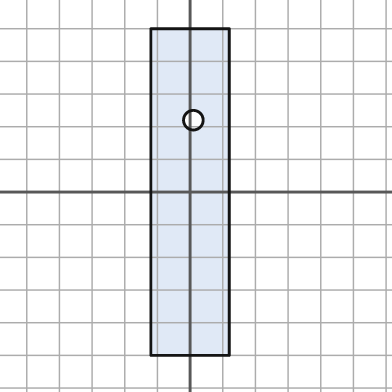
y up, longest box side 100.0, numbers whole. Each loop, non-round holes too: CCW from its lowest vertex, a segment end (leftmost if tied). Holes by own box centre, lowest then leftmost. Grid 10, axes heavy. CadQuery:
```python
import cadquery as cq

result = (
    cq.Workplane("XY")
    .moveTo(-12.0, -50.0)
    .lineTo(12.0, -50.0)
    .lineTo(12.0, 50.0)
    .lineTo(-12.0, 50.0)
    .close()
    .moveTo(1.0, 22.0)
    .circle(3.0)
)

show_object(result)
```